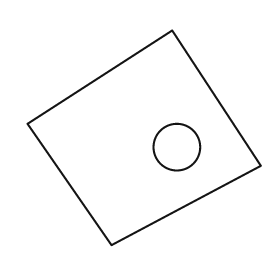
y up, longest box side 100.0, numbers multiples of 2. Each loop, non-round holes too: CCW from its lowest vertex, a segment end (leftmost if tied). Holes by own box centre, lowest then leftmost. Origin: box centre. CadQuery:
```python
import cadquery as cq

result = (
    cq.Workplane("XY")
    .moveTo(-14.0, -46.0)
    .lineTo(50.0, -12.0)
    .lineTo(12.0, 46.0)
    .lineTo(-50.0, 6.0)
    .close()
    .moveTo(14.0, -4.0)
    .circle(10.0)
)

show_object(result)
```